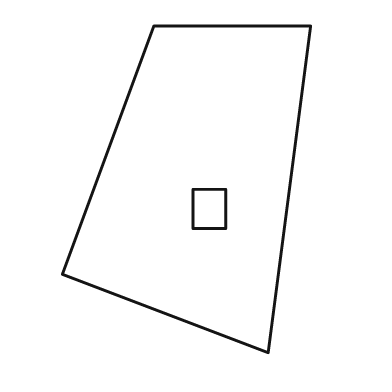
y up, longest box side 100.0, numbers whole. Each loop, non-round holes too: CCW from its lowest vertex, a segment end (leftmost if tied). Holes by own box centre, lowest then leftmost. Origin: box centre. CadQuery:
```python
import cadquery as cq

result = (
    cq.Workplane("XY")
    .moveTo(25.0, -50.0)
    .lineTo(38.0, 50.0)
    .lineTo(-10.0, 50.0)
    .lineTo(-38.0, -26.0)
    .close()
    .moveTo(2.0, -12.0)
    .lineTo(12.0, -12.0)
    .lineTo(12.0, 0.0)
    .lineTo(2.0, 0.0)
    .close()
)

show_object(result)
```